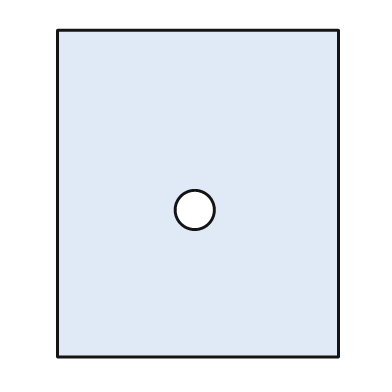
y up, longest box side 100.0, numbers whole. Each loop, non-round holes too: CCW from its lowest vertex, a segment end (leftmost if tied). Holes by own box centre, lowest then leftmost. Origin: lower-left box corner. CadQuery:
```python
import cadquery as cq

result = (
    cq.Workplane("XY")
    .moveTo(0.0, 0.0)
    .lineTo(86.0, 0.0)
    .lineTo(86.0, 100.0)
    .lineTo(0.0, 100.0)
    .close()
    .moveTo(42.0, 45.0)
    .circle(6.0)
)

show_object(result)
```